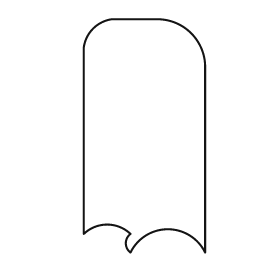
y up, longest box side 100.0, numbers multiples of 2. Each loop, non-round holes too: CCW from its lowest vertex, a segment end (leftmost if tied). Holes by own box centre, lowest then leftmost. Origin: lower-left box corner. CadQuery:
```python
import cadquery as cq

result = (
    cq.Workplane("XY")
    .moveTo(20.0, 0.0)
    .threePointArc((36.0, 10.0), (52.0, 0.0))
    .lineTo(52.0, 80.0)
    .threePointArc((46.0, 94.0), (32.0, 100.0))
    .lineTo(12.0, 100.0)
    .threePointArc((4.0, 96.0), (0.0, 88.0))
    .lineTo(0.0, 8.0)
    .threePointArc((10.0, 12.0), (20.0, 8.0))
    .threePointArc((18.0, 4.0), (20.0, 0.0))
    .close()
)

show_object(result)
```